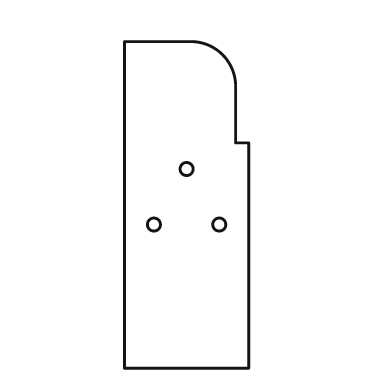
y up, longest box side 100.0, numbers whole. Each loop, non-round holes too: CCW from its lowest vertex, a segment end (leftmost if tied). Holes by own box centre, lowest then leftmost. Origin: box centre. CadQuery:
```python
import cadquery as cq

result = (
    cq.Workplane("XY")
    .moveTo(-19.0, -50.0)
    .lineTo(19.0, -50.0)
    .lineTo(19.0, 19.0)
    .lineTo(15.0, 19.0)
    .lineTo(15.0, 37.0)
    .threePointArc((11.0, 46.0), (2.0, 50.0))
    .lineTo(-19.0, 50.0)
    .close()
    .moveTo(-10.0, -6.0)
    .circle(2.0)
    .moveTo(10.0, -6.0)
    .circle(2.0)
    .moveTo(0.0, 11.0)
    .circle(2.0)
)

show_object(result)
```